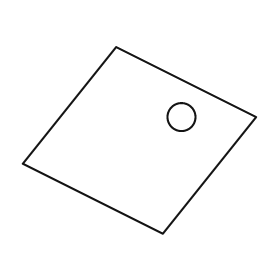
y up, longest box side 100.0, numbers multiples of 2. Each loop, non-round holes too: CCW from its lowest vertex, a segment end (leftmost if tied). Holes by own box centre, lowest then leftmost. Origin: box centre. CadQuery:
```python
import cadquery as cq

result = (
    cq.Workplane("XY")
    .moveTo(10.0, -40.0)
    .lineTo(50.0, 10.0)
    .lineTo(-10.0, 40.0)
    .lineTo(-50.0, -10.0)
    .close()
    .moveTo(18.0, 10.0)
    .circle(6.0)
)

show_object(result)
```